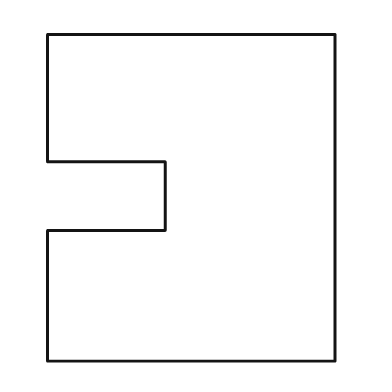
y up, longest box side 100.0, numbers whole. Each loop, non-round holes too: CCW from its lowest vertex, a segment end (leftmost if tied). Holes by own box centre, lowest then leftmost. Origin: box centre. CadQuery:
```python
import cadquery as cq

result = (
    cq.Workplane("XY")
    .moveTo(-44.0, -50.0)
    .lineTo(44.0, -50.0)
    .lineTo(44.0, 50.0)
    .lineTo(-44.0, 50.0)
    .lineTo(-44.0, 11.0)
    .lineTo(-8.0, 11.0)
    .lineTo(-8.0, -10.0)
    .lineTo(-44.0, -10.0)
    .close()
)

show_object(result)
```